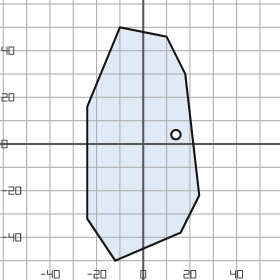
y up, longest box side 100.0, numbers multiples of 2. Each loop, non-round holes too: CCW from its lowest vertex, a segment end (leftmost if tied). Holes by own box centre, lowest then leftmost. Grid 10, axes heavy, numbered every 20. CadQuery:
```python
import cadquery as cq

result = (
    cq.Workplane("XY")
    .moveTo(-12.0, -50.0)
    .lineTo(16.0, -38.0)
    .lineTo(24.0, -22.0)
    .lineTo(18.0, 30.0)
    .lineTo(10.0, 46.0)
    .lineTo(-10.0, 50.0)
    .lineTo(-24.0, 16.0)
    .lineTo(-24.0, -32.0)
    .close()
    .moveTo(14.0, 4.0)
    .circle(2.0)
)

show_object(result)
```